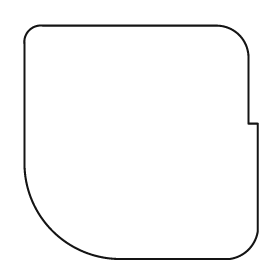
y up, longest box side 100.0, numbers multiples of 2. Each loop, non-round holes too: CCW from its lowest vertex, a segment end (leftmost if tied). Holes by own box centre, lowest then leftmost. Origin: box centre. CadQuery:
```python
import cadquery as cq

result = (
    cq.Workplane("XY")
    .moveTo(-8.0, -50.0)
    .lineTo(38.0, -50.0)
    .threePointArc((46.0, -46.0), (50.0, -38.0))
    .lineTo(50.0, 8.0)
    .lineTo(46.0, 8.0)
    .lineTo(46.0, 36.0)
    .threePointArc((42.0, 46.0), (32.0, 50.0))
    .lineTo(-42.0, 50.0)
    .threePointArc((-48.0, 48.0), (-50.0, 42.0))
    .lineTo(-50.0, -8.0)
    .threePointArc((-38.0, -38.0), (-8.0, -50.0))
    .close()
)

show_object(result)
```